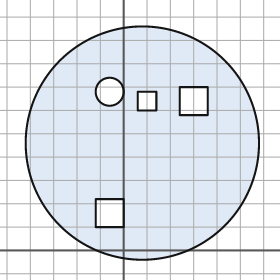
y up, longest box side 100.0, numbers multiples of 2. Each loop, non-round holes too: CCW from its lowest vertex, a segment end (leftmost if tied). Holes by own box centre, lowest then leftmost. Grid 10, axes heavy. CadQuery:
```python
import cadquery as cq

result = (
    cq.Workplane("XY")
    .moveTo(8.0, 46.0)
    .circle(50.0)
    .moveTo(-12.0, 10.0)
    .lineTo(0.0, 10.0)
    .lineTo(0.0, 22.0)
    .lineTo(-12.0, 22.0)
    .close()
    .moveTo(6.0, 60.0)
    .lineTo(14.0, 60.0)
    .lineTo(14.0, 68.0)
    .lineTo(6.0, 68.0)
    .close()
    .moveTo(24.0, 58.0)
    .lineTo(36.0, 58.0)
    .lineTo(36.0, 70.0)
    .lineTo(24.0, 70.0)
    .close()
    .moveTo(-6.0, 68.0)
    .circle(6.0)
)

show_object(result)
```